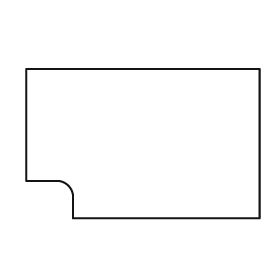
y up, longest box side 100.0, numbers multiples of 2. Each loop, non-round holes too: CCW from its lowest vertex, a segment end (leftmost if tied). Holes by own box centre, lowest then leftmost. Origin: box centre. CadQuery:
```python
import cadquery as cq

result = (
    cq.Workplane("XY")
    .moveTo(-30.0, -32.0)
    .lineTo(50.0, -32.0)
    .lineTo(50.0, 32.0)
    .lineTo(-50.0, 32.0)
    .lineTo(-50.0, -16.0)
    .lineTo(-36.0, -16.0)
    .threePointArc((-32.0, -18.0), (-30.0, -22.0))
    .close()
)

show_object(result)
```